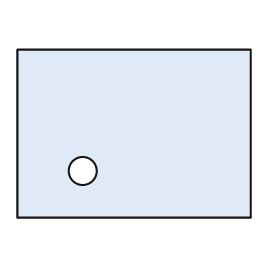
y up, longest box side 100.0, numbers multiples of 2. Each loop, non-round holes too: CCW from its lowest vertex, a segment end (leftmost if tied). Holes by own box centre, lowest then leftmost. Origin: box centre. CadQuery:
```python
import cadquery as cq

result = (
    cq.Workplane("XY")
    .moveTo(-50.0, -36.0)
    .lineTo(50.0, -36.0)
    .lineTo(50.0, 36.0)
    .lineTo(-50.0, 36.0)
    .close()
    .moveTo(-22.0, -16.0)
    .circle(6.0)
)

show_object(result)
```